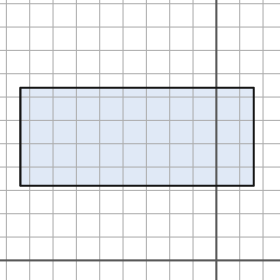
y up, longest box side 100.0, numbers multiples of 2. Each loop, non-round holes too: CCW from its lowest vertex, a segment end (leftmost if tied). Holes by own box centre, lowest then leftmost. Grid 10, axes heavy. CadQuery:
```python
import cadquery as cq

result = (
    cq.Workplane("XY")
    .moveTo(-84.0, 32.0)
    .lineTo(16.0, 32.0)
    .lineTo(16.0, 74.0)
    .lineTo(-84.0, 74.0)
    .close()
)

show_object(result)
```